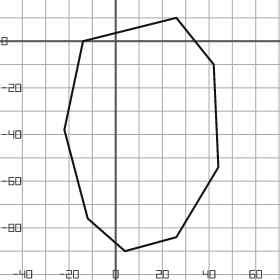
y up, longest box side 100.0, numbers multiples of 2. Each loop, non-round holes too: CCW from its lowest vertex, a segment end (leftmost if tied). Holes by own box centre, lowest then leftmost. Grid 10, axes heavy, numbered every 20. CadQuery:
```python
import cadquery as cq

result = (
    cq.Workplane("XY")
    .moveTo(4.0, -90.0)
    .lineTo(26.0, -84.0)
    .lineTo(44.0, -54.0)
    .lineTo(42.0, -10.0)
    .lineTo(26.0, 10.0)
    .lineTo(-14.0, 0.0)
    .lineTo(-22.0, -38.0)
    .lineTo(-12.0, -76.0)
    .close()
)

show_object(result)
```